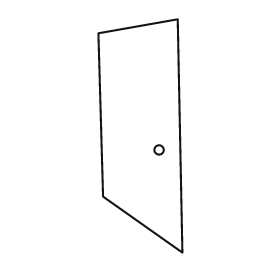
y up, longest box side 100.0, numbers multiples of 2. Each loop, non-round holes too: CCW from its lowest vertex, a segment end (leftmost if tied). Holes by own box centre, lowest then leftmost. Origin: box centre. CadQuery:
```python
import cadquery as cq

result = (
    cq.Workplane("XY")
    .moveTo(18.0, -50.0)
    .lineTo(16.0, 50.0)
    .lineTo(-18.0, 44.0)
    .lineTo(-16.0, -26.0)
    .close()
    .moveTo(8.0, -6.0)
    .circle(2.0)
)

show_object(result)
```